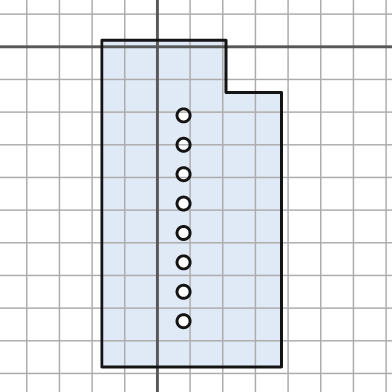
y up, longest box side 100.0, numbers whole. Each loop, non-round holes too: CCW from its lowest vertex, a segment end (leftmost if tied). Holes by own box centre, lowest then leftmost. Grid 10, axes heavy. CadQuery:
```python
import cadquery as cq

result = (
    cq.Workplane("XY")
    .moveTo(-17.0, -98.0)
    .lineTo(38.0, -98.0)
    .lineTo(38.0, -14.0)
    .lineTo(21.0, -14.0)
    .lineTo(21.0, 2.0)
    .lineTo(-17.0, 2.0)
    .close()
    .moveTo(8.0, -84.0)
    .circle(2.0)
    .moveTo(8.0, -75.0)
    .circle(2.0)
    .moveTo(8.0, -66.0)
    .circle(2.0)
    .moveTo(8.0, -57.0)
    .circle(2.0)
    .moveTo(8.0, -48.0)
    .circle(2.0)
    .moveTo(8.0, -39.0)
    .circle(2.0)
    .moveTo(8.0, -30.0)
    .circle(2.0)
    .moveTo(8.0, -21.0)
    .circle(2.0)
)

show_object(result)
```